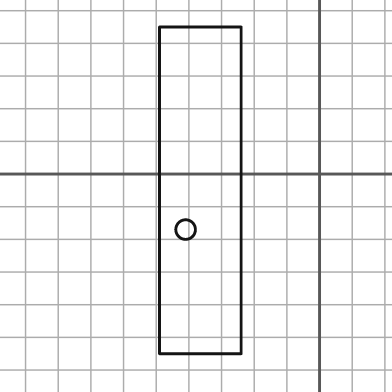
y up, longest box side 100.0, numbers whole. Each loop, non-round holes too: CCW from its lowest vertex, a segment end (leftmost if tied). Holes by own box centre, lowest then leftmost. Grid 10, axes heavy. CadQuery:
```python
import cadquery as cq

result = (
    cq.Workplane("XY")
    .moveTo(-49.0, -55.0)
    .lineTo(-24.0, -55.0)
    .lineTo(-24.0, 45.0)
    .lineTo(-49.0, 45.0)
    .close()
    .moveTo(-41.0, -17.0)
    .circle(3.0)
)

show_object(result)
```